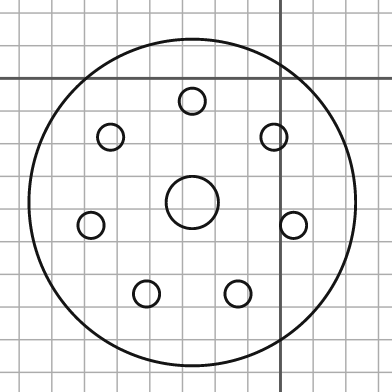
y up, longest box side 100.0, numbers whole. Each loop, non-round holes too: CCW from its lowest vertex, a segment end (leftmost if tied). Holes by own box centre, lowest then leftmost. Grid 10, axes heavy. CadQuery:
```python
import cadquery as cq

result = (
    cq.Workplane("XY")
    .moveTo(-27.0, -38.0)
    .circle(50.0)
    .moveTo(-41.0, -66.0)
    .circle(4.0)
    .moveTo(-13.0, -66.0)
    .circle(4.0)
    .moveTo(-58.0, -45.0)
    .circle(4.0)
    .moveTo(4.0, -45.0)
    .circle(4.0)
    .moveTo(-27.0, -38.0)
    .circle(8.0)
    .moveTo(-52.0, -18.0)
    .circle(4.0)
    .moveTo(-2.0, -18.0)
    .circle(4.0)
    .moveTo(-27.0, -7.0)
    .circle(4.0)
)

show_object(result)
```